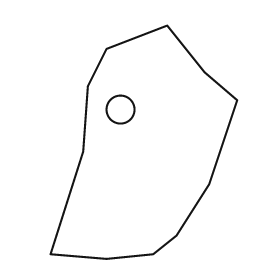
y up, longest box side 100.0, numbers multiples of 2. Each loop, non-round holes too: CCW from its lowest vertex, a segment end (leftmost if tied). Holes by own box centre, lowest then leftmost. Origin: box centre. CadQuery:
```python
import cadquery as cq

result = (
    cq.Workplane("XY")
    .moveTo(-16.0, -50.0)
    .lineTo(4.0, -48.0)
    .lineTo(14.0, -40.0)
    .lineTo(28.0, -18.0)
    .lineTo(40.0, 18.0)
    .lineTo(26.0, 30.0)
    .lineTo(10.0, 50.0)
    .lineTo(-16.0, 40.0)
    .lineTo(-24.0, 24.0)
    .lineTo(-26.0, -4.0)
    .lineTo(-40.0, -48.0)
    .close()
    .moveTo(-10.0, 14.0)
    .circle(6.0)
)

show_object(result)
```